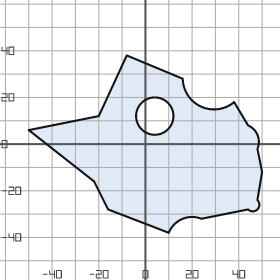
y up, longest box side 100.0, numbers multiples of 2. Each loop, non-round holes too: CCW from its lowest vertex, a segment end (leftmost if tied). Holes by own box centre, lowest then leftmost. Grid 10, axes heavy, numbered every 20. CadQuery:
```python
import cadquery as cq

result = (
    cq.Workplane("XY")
    .moveTo(10.0, -38.0)
    .threePointArc((16.0, -32.0), (24.0, -32.0))
    .lineTo(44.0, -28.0)
    .threePointArc((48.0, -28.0), (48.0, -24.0))
    .lineTo(50.0, -12.0)
    .lineTo(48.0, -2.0)
    .threePointArc((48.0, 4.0), (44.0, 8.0))
    .lineTo(38.0, 18.0)
    .threePointArc((24.0, 16.0), (16.0, 28.0))
    .lineTo(-8.0, 38.0)
    .lineTo(-20.0, 12.0)
    .lineTo(-50.0, 6.0)
    .lineTo(-22.0, -16.0)
    .lineTo(-16.0, -28.0)
    .close()
    .moveTo(4.0, 12.0)
    .circle(8.0)
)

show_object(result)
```